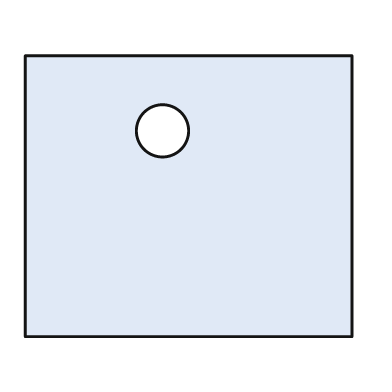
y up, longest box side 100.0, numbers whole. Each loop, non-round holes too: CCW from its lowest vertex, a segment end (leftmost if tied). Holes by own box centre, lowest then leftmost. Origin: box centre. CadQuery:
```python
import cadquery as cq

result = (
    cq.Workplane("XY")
    .moveTo(-50.0, -43.0)
    .lineTo(50.0, -43.0)
    .lineTo(50.0, 43.0)
    .lineTo(-50.0, 43.0)
    .close()
    .moveTo(-8.0, 20.0)
    .circle(8.0)
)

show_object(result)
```